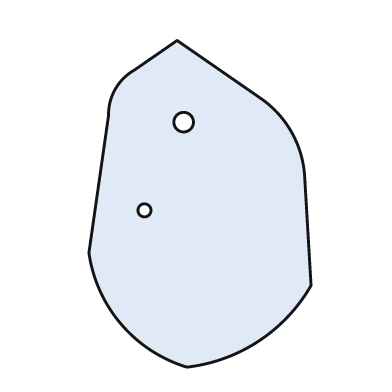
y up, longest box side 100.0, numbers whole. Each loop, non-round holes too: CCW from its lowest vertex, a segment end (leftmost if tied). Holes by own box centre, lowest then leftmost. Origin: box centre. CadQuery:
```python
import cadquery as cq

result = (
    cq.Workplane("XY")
    .moveTo(-4.0, -50.0)
    .threePointArc((18.0, -42.0), (34.0, -25.0))
    .lineTo(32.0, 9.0)
    .threePointArc((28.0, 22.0), (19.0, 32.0))
    .lineTo(-7.0, 50.0)
    .lineTo(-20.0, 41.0)
    .threePointArc((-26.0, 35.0), (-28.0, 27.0))
    .lineTo(-34.0, -15.0)
    .threePointArc((-24.0, -37.0), (-4.0, -50.0))
    .close()
    .moveTo(-17.0, -2.0)
    .circle(2.0)
    .moveTo(-5.0, 25.0)
    .circle(3.0)
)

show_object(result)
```